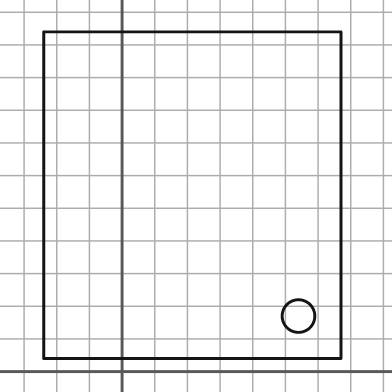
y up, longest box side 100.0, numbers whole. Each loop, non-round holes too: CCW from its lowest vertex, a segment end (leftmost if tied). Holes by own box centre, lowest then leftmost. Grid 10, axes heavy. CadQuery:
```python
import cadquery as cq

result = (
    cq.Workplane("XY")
    .moveTo(-24.0, 4.0)
    .lineTo(67.0, 4.0)
    .lineTo(67.0, 104.0)
    .lineTo(-24.0, 104.0)
    .close()
    .moveTo(54.0, 17.0)
    .circle(5.0)
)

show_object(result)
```